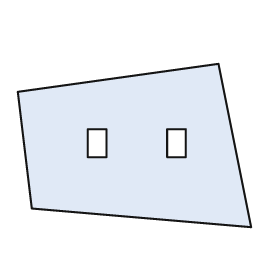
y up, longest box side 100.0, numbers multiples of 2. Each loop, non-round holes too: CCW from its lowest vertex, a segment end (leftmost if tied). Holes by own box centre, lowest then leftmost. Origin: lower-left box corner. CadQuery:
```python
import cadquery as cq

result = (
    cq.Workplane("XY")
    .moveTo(100.0, 0.0)
    .lineTo(86.0, 70.0)
    .lineTo(0.0, 58.0)
    .lineTo(6.0, 8.0)
    .close()
    .moveTo(30.0, 30.0)
    .lineTo(38.0, 30.0)
    .lineTo(38.0, 42.0)
    .lineTo(30.0, 42.0)
    .close()
    .moveTo(64.0, 30.0)
    .lineTo(72.0, 30.0)
    .lineTo(72.0, 42.0)
    .lineTo(64.0, 42.0)
    .close()
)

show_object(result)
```